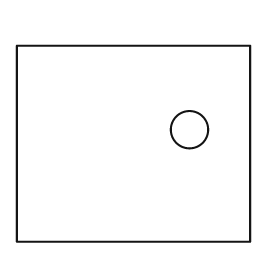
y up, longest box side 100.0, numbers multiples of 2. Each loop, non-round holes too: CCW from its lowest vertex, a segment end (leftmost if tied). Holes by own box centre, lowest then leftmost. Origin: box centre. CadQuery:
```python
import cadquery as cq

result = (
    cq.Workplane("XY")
    .moveTo(-50.0, -42.0)
    .lineTo(50.0, -42.0)
    .lineTo(50.0, 42.0)
    .lineTo(-50.0, 42.0)
    .close()
    .moveTo(24.0, 6.0)
    .circle(8.0)
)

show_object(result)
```